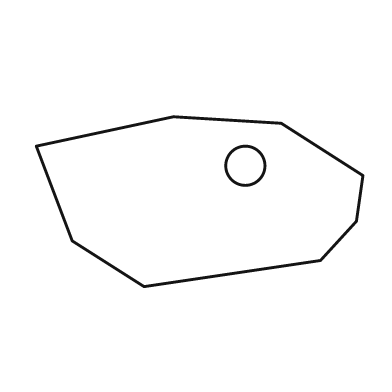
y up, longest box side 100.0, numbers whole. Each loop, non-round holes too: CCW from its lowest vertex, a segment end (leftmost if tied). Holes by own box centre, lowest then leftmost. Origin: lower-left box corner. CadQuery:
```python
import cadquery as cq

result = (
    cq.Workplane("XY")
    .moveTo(33.0, 0.0)
    .lineTo(87.0, 8.0)
    .lineTo(98.0, 20.0)
    .lineTo(100.0, 34.0)
    .lineTo(75.0, 50.0)
    .lineTo(42.0, 52.0)
    .lineTo(0.0, 43.0)
    .lineTo(11.0, 14.0)
    .close()
    .moveTo(64.0, 37.0)
    .circle(6.0)
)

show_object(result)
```